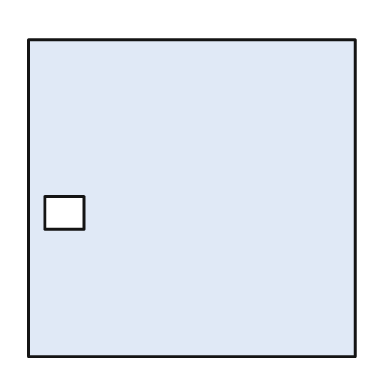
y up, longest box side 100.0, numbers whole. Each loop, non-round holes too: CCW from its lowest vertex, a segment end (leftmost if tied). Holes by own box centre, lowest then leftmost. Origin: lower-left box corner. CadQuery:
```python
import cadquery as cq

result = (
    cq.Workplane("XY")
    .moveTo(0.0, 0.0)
    .lineTo(100.0, 0.0)
    .lineTo(100.0, 97.0)
    .lineTo(0.0, 97.0)
    .close()
    .moveTo(5.0, 39.0)
    .lineTo(17.0, 39.0)
    .lineTo(17.0, 49.0)
    .lineTo(5.0, 49.0)
    .close()
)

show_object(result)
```